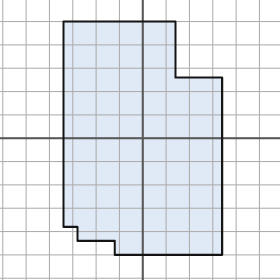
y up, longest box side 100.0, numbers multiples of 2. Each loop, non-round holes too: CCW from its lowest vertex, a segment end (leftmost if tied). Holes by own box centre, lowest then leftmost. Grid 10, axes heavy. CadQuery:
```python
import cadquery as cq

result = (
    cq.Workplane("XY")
    .moveTo(-12.0, -50.0)
    .lineTo(34.0, -50.0)
    .lineTo(34.0, 26.0)
    .lineTo(14.0, 26.0)
    .lineTo(14.0, 50.0)
    .lineTo(-34.0, 50.0)
    .lineTo(-34.0, -38.0)
    .lineTo(-28.0, -38.0)
    .lineTo(-28.0, -44.0)
    .lineTo(-12.0, -44.0)
    .close()
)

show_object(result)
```